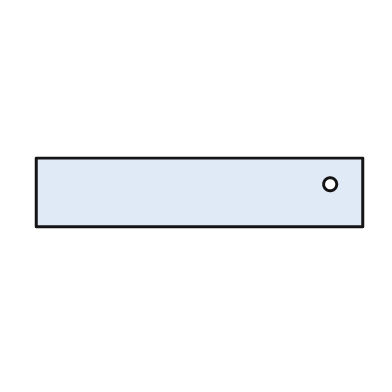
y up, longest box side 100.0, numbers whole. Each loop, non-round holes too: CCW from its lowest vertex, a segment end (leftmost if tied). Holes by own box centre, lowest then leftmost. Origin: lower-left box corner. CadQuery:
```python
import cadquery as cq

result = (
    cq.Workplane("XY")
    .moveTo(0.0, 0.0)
    .lineTo(100.0, 0.0)
    .lineTo(100.0, 21.0)
    .lineTo(0.0, 21.0)
    .close()
    .moveTo(90.0, 13.0)
    .circle(2.0)
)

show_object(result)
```